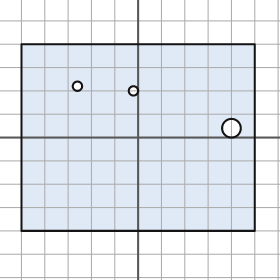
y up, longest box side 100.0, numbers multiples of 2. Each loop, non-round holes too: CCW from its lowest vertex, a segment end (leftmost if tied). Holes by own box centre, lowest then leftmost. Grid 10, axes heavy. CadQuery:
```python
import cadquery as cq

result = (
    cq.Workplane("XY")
    .moveTo(-50.0, -40.0)
    .lineTo(50.0, -40.0)
    .lineTo(50.0, 40.0)
    .lineTo(-50.0, 40.0)
    .close()
    .moveTo(40.0, 4.0)
    .circle(4.0)
    .moveTo(-2.0, 20.0)
    .circle(2.0)
    .moveTo(-26.0, 22.0)
    .circle(2.0)
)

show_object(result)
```